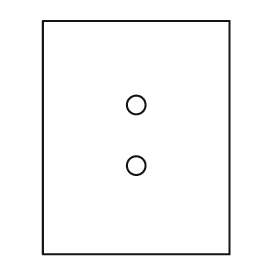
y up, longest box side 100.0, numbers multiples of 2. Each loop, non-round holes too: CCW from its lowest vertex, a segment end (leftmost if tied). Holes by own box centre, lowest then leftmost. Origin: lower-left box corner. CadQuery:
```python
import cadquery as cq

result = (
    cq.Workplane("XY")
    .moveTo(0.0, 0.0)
    .lineTo(80.0, 0.0)
    .lineTo(80.0, 100.0)
    .lineTo(0.0, 100.0)
    .close()
    .moveTo(40.0, 38.0)
    .circle(4.0)
    .moveTo(40.0, 64.0)
    .circle(4.0)
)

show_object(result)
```